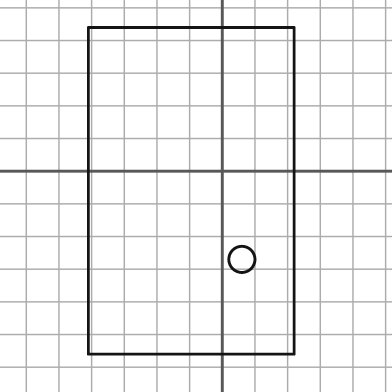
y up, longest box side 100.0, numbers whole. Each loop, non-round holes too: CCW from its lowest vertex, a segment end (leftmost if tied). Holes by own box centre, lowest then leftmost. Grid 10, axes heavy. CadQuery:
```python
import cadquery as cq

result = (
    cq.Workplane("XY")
    .moveTo(-41.0, -56.0)
    .lineTo(22.0, -56.0)
    .lineTo(22.0, 44.0)
    .lineTo(-41.0, 44.0)
    .close()
    .moveTo(6.0, -27.0)
    .circle(4.0)
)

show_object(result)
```